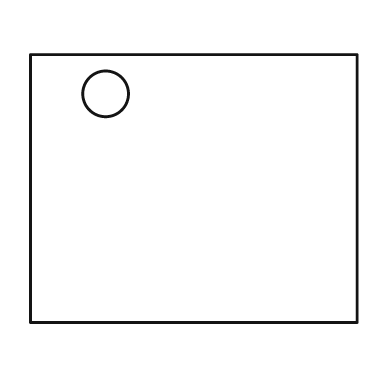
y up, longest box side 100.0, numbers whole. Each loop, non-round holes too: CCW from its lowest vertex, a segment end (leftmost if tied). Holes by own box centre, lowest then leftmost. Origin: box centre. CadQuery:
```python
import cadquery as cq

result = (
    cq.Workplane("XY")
    .moveTo(-50.0, -41.0)
    .lineTo(50.0, -41.0)
    .lineTo(50.0, 41.0)
    .lineTo(-50.0, 41.0)
    .close()
    .moveTo(-27.0, 29.0)
    .circle(7.0)
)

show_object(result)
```